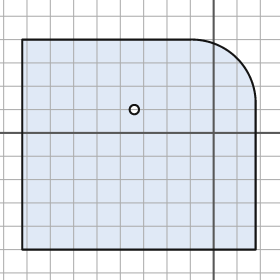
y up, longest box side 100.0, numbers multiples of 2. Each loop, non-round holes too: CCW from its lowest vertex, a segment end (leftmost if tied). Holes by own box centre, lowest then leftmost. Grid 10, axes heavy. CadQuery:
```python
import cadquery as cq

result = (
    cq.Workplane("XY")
    .moveTo(-82.0, -50.0)
    .lineTo(18.0, -50.0)
    .lineTo(18.0, 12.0)
    .threePointArc((10.0, 32.0), (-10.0, 40.0))
    .lineTo(-82.0, 40.0)
    .close()
    .moveTo(-34.0, 10.0)
    .circle(2.0)
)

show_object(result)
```